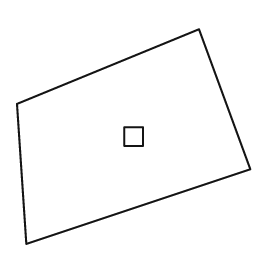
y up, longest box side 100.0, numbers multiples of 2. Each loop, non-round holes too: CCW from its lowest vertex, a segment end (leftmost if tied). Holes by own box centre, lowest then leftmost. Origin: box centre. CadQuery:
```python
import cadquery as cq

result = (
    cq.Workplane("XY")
    .moveTo(-46.0, -46.0)
    .lineTo(50.0, -14.0)
    .lineTo(28.0, 46.0)
    .lineTo(-50.0, 14.0)
    .close()
    .moveTo(-4.0, -4.0)
    .lineTo(4.0, -4.0)
    .lineTo(4.0, 4.0)
    .lineTo(-4.0, 4.0)
    .close()
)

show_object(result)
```